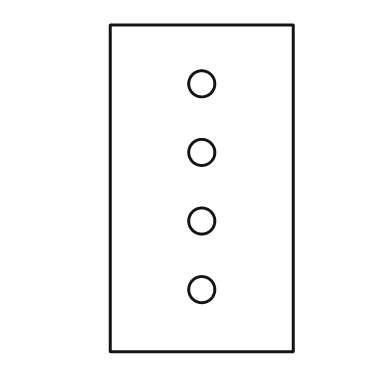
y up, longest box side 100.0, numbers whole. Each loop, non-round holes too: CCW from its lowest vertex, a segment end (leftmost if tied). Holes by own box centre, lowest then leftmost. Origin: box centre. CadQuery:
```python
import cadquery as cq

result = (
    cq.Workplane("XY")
    .moveTo(-28.0, -50.0)
    .lineTo(28.0, -50.0)
    .lineTo(28.0, 50.0)
    .lineTo(-28.0, 50.0)
    .close()
    .moveTo(0.0, -31.0)
    .circle(4.0)
    .moveTo(0.0, -10.0)
    .circle(4.0)
    .moveTo(0.0, 11.0)
    .circle(4.0)
    .moveTo(0.0, 32.0)
    .circle(4.0)
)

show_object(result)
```